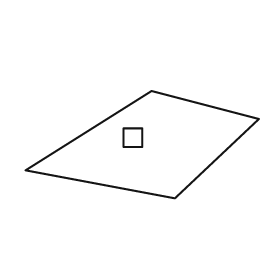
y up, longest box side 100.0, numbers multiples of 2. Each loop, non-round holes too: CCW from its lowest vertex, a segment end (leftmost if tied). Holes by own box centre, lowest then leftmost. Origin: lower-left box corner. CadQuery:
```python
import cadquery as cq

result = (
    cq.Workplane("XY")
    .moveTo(64.0, 0.0)
    .lineTo(100.0, 34.0)
    .lineTo(54.0, 46.0)
    .lineTo(0.0, 12.0)
    .close()
    .moveTo(42.0, 22.0)
    .lineTo(50.0, 22.0)
    .lineTo(50.0, 30.0)
    .lineTo(42.0, 30.0)
    .close()
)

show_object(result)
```